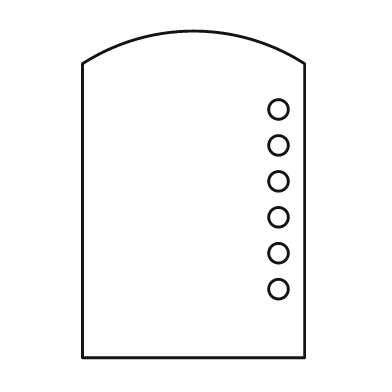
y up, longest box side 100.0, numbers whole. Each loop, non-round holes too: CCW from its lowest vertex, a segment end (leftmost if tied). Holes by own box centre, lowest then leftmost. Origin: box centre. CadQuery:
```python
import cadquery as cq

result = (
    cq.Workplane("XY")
    .moveTo(-34.0, -50.0)
    .lineTo(34.0, -50.0)
    .lineTo(34.0, 40.0)
    .threePointArc((0.0, 50.0), (-34.0, 40.0))
    .close()
    .moveTo(26.0, -29.0)
    .circle(3.0)
    .moveTo(26.0, -18.0)
    .circle(3.0)
    .moveTo(26.0, -7.0)
    .circle(3.0)
    .moveTo(26.0, 4.0)
    .circle(3.0)
    .moveTo(26.0, 15.0)
    .circle(3.0)
    .moveTo(26.0, 26.0)
    .circle(3.0)
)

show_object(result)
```